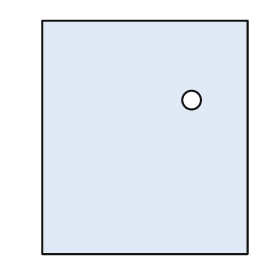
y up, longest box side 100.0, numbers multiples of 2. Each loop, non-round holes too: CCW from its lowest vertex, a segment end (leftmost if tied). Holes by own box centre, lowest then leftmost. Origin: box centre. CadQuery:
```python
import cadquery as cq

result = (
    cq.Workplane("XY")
    .moveTo(-44.0, -50.0)
    .lineTo(44.0, -50.0)
    .lineTo(44.0, 50.0)
    .lineTo(-44.0, 50.0)
    .close()
    .moveTo(20.0, 16.0)
    .circle(4.0)
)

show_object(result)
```